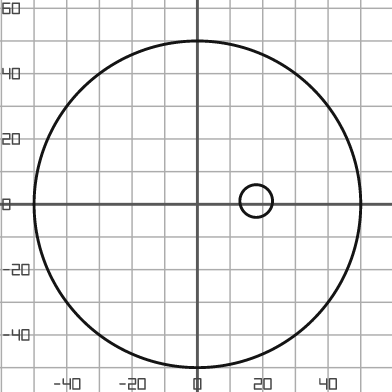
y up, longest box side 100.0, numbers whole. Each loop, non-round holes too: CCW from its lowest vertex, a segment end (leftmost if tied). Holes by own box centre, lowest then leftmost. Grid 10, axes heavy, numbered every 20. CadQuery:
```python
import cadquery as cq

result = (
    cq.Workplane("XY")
    .moveTo(0.0, 0.0)
    .circle(50.0)
    .moveTo(18.0, 1.0)
    .circle(5.0)
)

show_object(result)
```